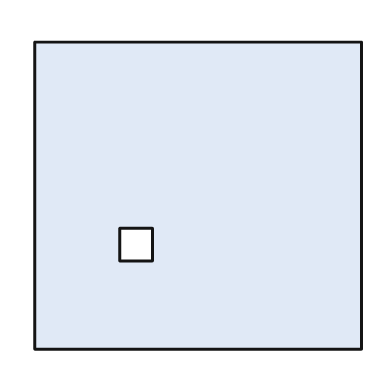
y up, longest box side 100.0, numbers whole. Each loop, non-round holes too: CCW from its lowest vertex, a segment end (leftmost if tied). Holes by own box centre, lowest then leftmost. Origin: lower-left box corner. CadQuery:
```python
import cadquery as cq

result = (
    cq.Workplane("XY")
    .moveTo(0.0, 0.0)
    .lineTo(100.0, 0.0)
    .lineTo(100.0, 94.0)
    .lineTo(0.0, 94.0)
    .close()
    .moveTo(26.0, 27.0)
    .lineTo(36.0, 27.0)
    .lineTo(36.0, 37.0)
    .lineTo(26.0, 37.0)
    .close()
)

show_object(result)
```